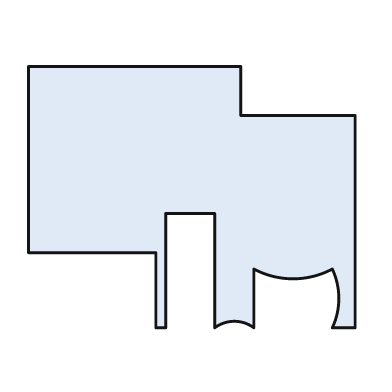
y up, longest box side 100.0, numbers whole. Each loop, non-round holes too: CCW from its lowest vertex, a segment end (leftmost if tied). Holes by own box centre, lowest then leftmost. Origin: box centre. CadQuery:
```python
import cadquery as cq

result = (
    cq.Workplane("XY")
    .moveTo(-11.0, -40.0)
    .lineTo(-8.0, -40.0)
    .lineTo(-8.0, -5.0)
    .lineTo(7.0, -5.0)
    .lineTo(7.0, -40.0)
    .threePointArc((13.0, -38.0), (19.0, -40.0))
    .lineTo(19.0, -22.0)
    .threePointArc((31.0, -25.0), (43.0, -22.0))
    .threePointArc((45.0, -31.0), (43.0, -40.0))
    .lineTo(50.0, -40.0)
    .lineTo(50.0, 25.0)
    .lineTo(15.0, 25.0)
    .lineTo(15.0, 40.0)
    .lineTo(-50.0, 40.0)
    .lineTo(-50.0, -17.0)
    .lineTo(-11.0, -17.0)
    .close()
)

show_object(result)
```